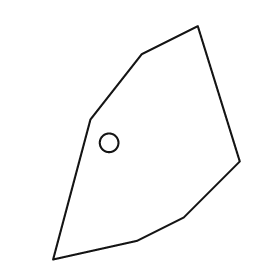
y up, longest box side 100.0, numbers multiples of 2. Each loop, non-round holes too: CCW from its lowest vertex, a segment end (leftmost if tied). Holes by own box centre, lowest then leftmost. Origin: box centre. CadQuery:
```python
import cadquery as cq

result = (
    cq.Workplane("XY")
    .moveTo(-40.0, -50.0)
    .lineTo(-4.0, -42.0)
    .lineTo(16.0, -32.0)
    .lineTo(40.0, -8.0)
    .lineTo(22.0, 50.0)
    .lineTo(-2.0, 38.0)
    .lineTo(-24.0, 10.0)
    .close()
    .moveTo(-16.0, 0.0)
    .circle(4.0)
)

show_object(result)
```